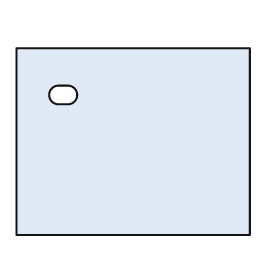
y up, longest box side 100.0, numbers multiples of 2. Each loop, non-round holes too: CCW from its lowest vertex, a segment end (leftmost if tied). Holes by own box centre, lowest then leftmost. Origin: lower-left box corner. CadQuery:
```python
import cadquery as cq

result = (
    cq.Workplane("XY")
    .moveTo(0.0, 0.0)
    .lineTo(100.0, 0.0)
    .lineTo(100.0, 80.0)
    .lineTo(0.0, 80.0)
    .close()
    .moveTo(18.0, 56.0)
    .lineTo(22.0, 56.0)
    .threePointArc((26.0, 60.0), (22.0, 64.0))
    .lineTo(18.0, 64.0)
    .threePointArc((14.0, 60.0), (18.0, 56.0))
    .close()
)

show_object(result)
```